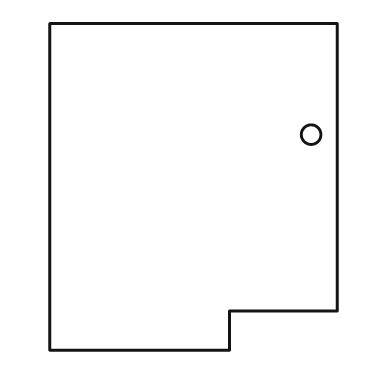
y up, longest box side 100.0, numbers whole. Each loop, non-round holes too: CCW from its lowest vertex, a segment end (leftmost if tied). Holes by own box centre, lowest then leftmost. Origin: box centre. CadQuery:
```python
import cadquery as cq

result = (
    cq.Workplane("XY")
    .moveTo(-44.0, -50.0)
    .lineTo(11.0, -50.0)
    .lineTo(11.0, -38.0)
    .lineTo(44.0, -38.0)
    .lineTo(44.0, 50.0)
    .lineTo(-44.0, 50.0)
    .close()
    .moveTo(36.0, 16.0)
    .circle(3.0)
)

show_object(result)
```